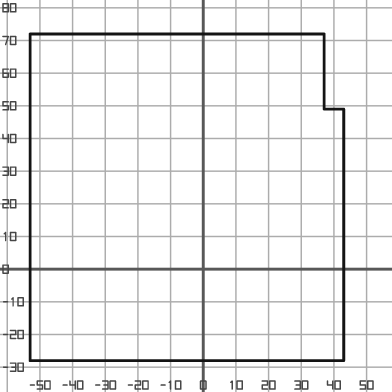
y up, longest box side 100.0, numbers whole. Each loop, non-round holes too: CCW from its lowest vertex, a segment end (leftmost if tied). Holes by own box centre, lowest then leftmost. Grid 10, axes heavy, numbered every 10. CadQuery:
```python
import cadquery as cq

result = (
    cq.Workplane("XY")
    .moveTo(-53.0, -28.0)
    .lineTo(43.0, -28.0)
    .lineTo(43.0, 49.0)
    .lineTo(37.0, 49.0)
    .lineTo(37.0, 72.0)
    .lineTo(-53.0, 72.0)
    .close()
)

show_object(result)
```